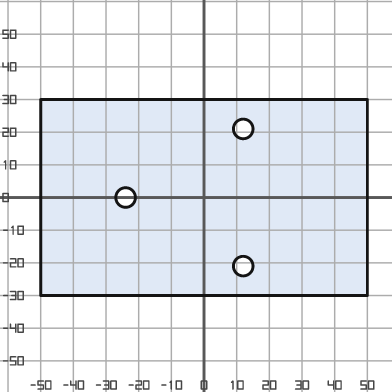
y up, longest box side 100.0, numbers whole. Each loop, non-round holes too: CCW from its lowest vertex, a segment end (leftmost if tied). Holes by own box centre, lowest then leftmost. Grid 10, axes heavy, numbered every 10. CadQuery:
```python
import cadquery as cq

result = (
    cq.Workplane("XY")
    .moveTo(-50.0, -30.0)
    .lineTo(50.0, -30.0)
    .lineTo(50.0, 30.0)
    .lineTo(-50.0, 30.0)
    .close()
    .moveTo(12.0, -21.0)
    .circle(3.0)
    .moveTo(-24.0, 0.0)
    .circle(3.0)
    .moveTo(12.0, 21.0)
    .circle(3.0)
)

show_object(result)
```